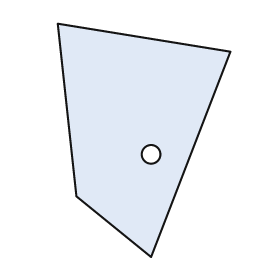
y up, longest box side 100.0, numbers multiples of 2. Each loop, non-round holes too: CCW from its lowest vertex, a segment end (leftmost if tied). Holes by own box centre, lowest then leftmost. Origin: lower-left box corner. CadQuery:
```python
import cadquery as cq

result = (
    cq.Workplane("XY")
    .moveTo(40.0, 0.0)
    .lineTo(74.0, 88.0)
    .lineTo(0.0, 100.0)
    .lineTo(8.0, 26.0)
    .close()
    .moveTo(40.0, 44.0)
    .circle(4.0)
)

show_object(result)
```